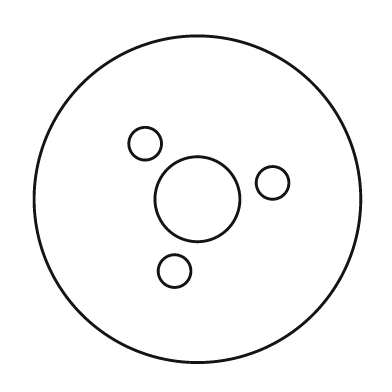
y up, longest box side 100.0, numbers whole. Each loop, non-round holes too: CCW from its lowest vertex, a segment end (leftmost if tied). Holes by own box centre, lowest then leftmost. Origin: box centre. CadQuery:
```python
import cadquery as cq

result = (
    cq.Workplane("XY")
    .moveTo(0.0, 0.0)
    .circle(50.0)
    .moveTo(-7.0, -22.0)
    .circle(5.0)
    .moveTo(0.0, 0.0)
    .circle(13.0)
    .moveTo(23.0, 5.0)
    .circle(5.0)
    .moveTo(-16.0, 17.0)
    .circle(5.0)
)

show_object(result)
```